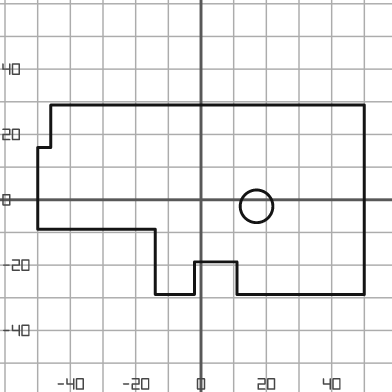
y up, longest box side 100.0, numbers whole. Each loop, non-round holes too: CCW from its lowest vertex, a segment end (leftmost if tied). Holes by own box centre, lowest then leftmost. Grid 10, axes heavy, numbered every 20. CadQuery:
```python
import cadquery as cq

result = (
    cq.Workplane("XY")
    .moveTo(-14.0, -29.0)
    .lineTo(-2.0, -29.0)
    .lineTo(-2.0, -19.0)
    .lineTo(11.0, -19.0)
    .lineTo(11.0, -29.0)
    .lineTo(50.0, -29.0)
    .lineTo(50.0, 29.0)
    .lineTo(-46.0, 29.0)
    .lineTo(-46.0, 16.0)
    .lineTo(-50.0, 16.0)
    .lineTo(-50.0, -9.0)
    .lineTo(-14.0, -9.0)
    .close()
    .moveTo(17.0, -2.0)
    .circle(5.0)
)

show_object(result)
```